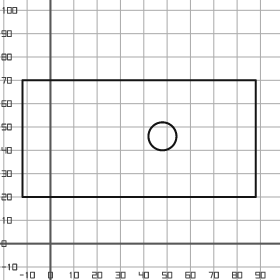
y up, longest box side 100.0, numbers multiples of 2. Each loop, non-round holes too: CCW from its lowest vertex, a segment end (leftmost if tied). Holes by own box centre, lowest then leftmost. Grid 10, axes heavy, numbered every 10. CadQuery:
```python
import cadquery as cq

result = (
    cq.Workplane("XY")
    .moveTo(-12.0, 20.0)
    .lineTo(88.0, 20.0)
    .lineTo(88.0, 70.0)
    .lineTo(-12.0, 70.0)
    .close()
    .moveTo(48.0, 46.0)
    .circle(6.0)
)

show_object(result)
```